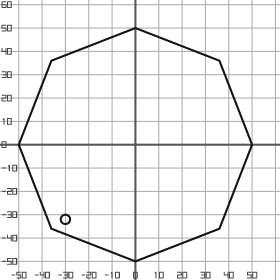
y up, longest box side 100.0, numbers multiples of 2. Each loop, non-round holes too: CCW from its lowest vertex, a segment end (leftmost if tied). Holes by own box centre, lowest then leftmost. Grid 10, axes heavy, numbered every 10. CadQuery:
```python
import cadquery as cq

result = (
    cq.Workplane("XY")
    .moveTo(0.0, -50.0)
    .lineTo(36.0, -36.0)
    .lineTo(50.0, 0.0)
    .lineTo(36.0, 36.0)
    .lineTo(0.0, 50.0)
    .lineTo(-36.0, 36.0)
    .lineTo(-50.0, 0.0)
    .lineTo(-36.0, -36.0)
    .close()
    .moveTo(-30.0, -32.0)
    .circle(2.0)
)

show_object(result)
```